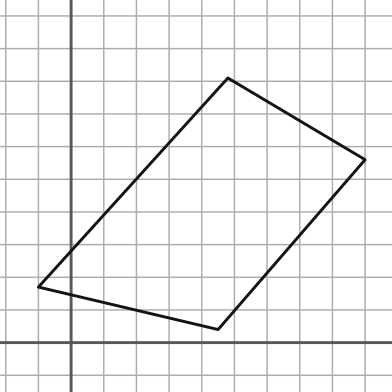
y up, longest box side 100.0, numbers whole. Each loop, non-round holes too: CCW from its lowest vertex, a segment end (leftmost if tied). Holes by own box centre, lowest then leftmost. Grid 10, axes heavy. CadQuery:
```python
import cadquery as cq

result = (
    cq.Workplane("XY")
    .moveTo(45.0, 4.0)
    .lineTo(90.0, 56.0)
    .lineTo(48.0, 81.0)
    .lineTo(-10.0, 17.0)
    .close()
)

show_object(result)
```